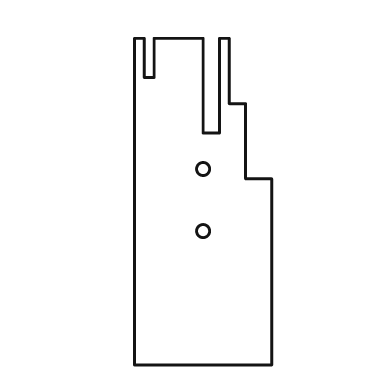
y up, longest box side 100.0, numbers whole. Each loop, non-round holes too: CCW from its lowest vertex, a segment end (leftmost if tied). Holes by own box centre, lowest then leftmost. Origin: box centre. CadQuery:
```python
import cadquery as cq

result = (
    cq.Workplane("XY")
    .moveTo(-21.0, -50.0)
    .lineTo(21.0, -50.0)
    .lineTo(21.0, 7.0)
    .lineTo(13.0, 7.0)
    .lineTo(13.0, 30.0)
    .lineTo(8.0, 30.0)
    .lineTo(8.0, 50.0)
    .lineTo(5.0, 50.0)
    .lineTo(5.0, 21.0)
    .lineTo(0.0, 21.0)
    .lineTo(0.0, 50.0)
    .lineTo(-15.0, 50.0)
    .lineTo(-15.0, 38.0)
    .lineTo(-18.0, 38.0)
    .lineTo(-18.0, 50.0)
    .lineTo(-21.0, 50.0)
    .close()
    .moveTo(0.0, -9.0)
    .circle(2.0)
    .moveTo(0.0, 10.0)
    .circle(2.0)
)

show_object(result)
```